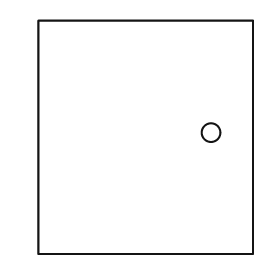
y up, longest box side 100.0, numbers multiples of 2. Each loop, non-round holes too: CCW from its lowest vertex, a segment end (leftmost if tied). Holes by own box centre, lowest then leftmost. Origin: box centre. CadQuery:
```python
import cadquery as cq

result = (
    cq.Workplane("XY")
    .moveTo(-46.0, -50.0)
    .lineTo(46.0, -50.0)
    .lineTo(46.0, 50.0)
    .lineTo(-46.0, 50.0)
    .close()
    .moveTo(28.0, 2.0)
    .circle(4.0)
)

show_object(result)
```